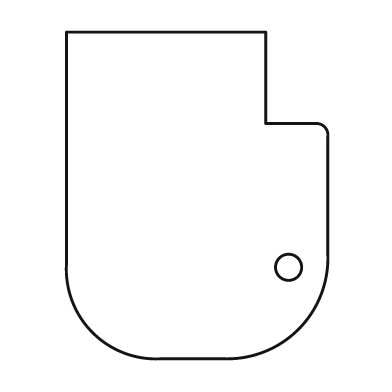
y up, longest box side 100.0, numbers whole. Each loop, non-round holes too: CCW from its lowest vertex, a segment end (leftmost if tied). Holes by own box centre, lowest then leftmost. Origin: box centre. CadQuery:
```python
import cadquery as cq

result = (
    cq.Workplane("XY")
    .moveTo(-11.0, -50.0)
    .lineTo(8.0, -50.0)
    .threePointArc((31.0, -41.0), (40.0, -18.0))
    .lineTo(40.0, 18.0)
    .threePointArc((39.0, 21.0), (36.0, 22.0))
    .lineTo(21.0, 22.0)
    .lineTo(21.0, 50.0)
    .lineTo(-40.0, 50.0)
    .lineTo(-40.0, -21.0)
    .threePointArc((-32.0, -42.0), (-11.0, -50.0))
    .close()
    .moveTo(28.0, -22.0)
    .circle(4.0)
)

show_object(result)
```